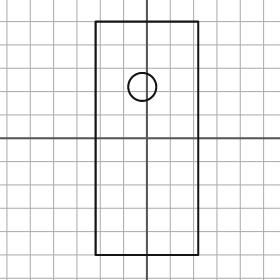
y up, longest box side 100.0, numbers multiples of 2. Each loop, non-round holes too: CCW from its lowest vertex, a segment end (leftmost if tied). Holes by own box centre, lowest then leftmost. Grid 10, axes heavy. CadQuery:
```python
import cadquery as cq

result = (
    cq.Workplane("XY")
    .moveTo(-22.0, -50.0)
    .lineTo(22.0, -50.0)
    .lineTo(22.0, 50.0)
    .lineTo(-22.0, 50.0)
    .close()
    .moveTo(-2.0, 22.0)
    .circle(6.0)
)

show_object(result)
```